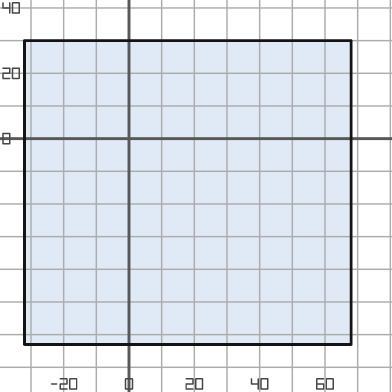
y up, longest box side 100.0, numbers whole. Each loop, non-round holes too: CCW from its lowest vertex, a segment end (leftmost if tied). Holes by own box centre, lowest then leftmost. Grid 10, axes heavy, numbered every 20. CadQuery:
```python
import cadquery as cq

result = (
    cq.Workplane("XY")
    .moveTo(-32.0, -63.0)
    .lineTo(68.0, -63.0)
    .lineTo(68.0, 30.0)
    .lineTo(-32.0, 30.0)
    .close()
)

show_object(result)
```